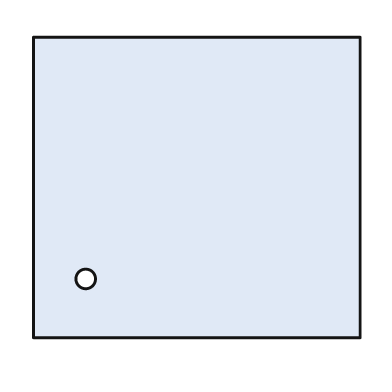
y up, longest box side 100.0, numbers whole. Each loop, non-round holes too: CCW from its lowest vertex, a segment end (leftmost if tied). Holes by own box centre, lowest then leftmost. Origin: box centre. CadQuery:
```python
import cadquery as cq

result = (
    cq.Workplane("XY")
    .moveTo(-50.0, -46.0)
    .lineTo(50.0, -46.0)
    .lineTo(50.0, 46.0)
    .lineTo(-50.0, 46.0)
    .close()
    .moveTo(-34.0, -28.0)
    .circle(3.0)
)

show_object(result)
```